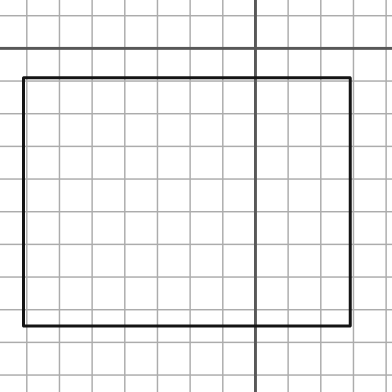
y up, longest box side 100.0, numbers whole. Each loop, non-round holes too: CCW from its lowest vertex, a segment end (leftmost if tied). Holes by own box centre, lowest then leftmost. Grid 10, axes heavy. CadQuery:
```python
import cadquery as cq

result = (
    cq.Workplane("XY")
    .moveTo(-71.0, -85.0)
    .lineTo(29.0, -85.0)
    .lineTo(29.0, -9.0)
    .lineTo(-71.0, -9.0)
    .close()
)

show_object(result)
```